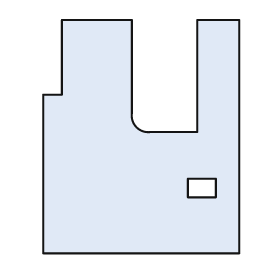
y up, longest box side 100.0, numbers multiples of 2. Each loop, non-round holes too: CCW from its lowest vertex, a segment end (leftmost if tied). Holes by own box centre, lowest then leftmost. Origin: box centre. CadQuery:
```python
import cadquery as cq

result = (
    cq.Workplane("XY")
    .moveTo(-42.0, -50.0)
    .lineTo(42.0, -50.0)
    .lineTo(42.0, 50.0)
    .lineTo(24.0, 50.0)
    .lineTo(24.0, 2.0)
    .lineTo(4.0, 2.0)
    .threePointArc((-2.0, 4.0), (-4.0, 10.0))
    .lineTo(-4.0, 50.0)
    .lineTo(-34.0, 50.0)
    .lineTo(-34.0, 18.0)
    .lineTo(-42.0, 18.0)
    .close()
    .moveTo(20.0, -26.0)
    .lineTo(32.0, -26.0)
    .lineTo(32.0, -18.0)
    .lineTo(20.0, -18.0)
    .close()
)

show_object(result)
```